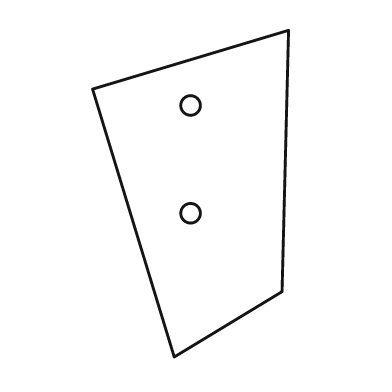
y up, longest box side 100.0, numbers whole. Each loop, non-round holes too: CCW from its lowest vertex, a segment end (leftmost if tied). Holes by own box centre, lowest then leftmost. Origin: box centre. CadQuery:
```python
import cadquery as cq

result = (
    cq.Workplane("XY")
    .moveTo(-5.0, -50.0)
    .lineTo(28.0, -30.0)
    .lineTo(30.0, 50.0)
    .lineTo(-30.0, 32.0)
    .close()
    .moveTo(0.0, -6.0)
    .circle(3.0)
    .moveTo(0.0, 27.0)
    .circle(3.0)
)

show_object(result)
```